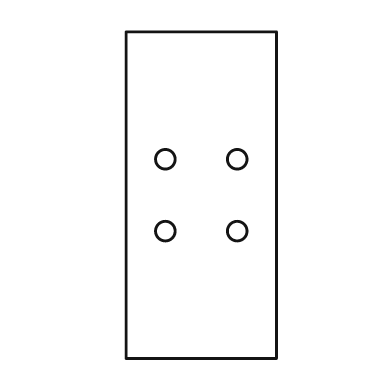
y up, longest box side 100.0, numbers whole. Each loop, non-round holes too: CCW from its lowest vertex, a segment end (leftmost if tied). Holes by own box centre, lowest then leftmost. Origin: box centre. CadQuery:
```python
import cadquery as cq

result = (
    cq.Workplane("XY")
    .moveTo(-23.0, -50.0)
    .lineTo(23.0, -50.0)
    .lineTo(23.0, 50.0)
    .lineTo(-23.0, 50.0)
    .close()
    .moveTo(-11.0, -11.0)
    .circle(3.0)
    .moveTo(11.0, -11.0)
    .circle(3.0)
    .moveTo(-11.0, 11.0)
    .circle(3.0)
    .moveTo(11.0, 11.0)
    .circle(3.0)
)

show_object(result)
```